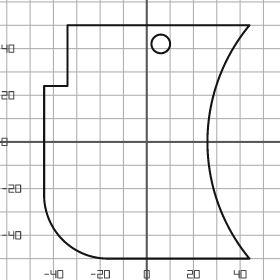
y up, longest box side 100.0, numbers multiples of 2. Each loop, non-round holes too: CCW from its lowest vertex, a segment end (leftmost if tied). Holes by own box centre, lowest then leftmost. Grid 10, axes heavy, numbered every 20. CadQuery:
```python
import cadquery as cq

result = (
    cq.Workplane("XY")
    .moveTo(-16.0, -50.0)
    .lineTo(44.0, -50.0)
    .threePointArc((26.0, 0.0), (44.0, 50.0))
    .lineTo(-34.0, 50.0)
    .lineTo(-34.0, 24.0)
    .lineTo(-44.0, 24.0)
    .lineTo(-44.0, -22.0)
    .threePointArc((-36.0, -42.0), (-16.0, -50.0))
    .close()
    .moveTo(6.0, 42.0)
    .circle(4.0)
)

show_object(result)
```